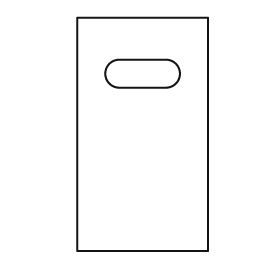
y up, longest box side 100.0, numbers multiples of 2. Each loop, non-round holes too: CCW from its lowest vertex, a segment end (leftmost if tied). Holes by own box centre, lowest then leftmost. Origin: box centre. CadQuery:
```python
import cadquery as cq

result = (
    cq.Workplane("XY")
    .moveTo(-28.0, -50.0)
    .lineTo(28.0, -50.0)
    .lineTo(28.0, 50.0)
    .lineTo(-28.0, 50.0)
    .close()
    .moveTo(-10.0, 20.0)
    .lineTo(10.0, 20.0)
    .threePointArc((16.0, 26.0), (10.0, 32.0))
    .lineTo(-10.0, 32.0)
    .threePointArc((-16.0, 26.0), (-10.0, 20.0))
    .close()
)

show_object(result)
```